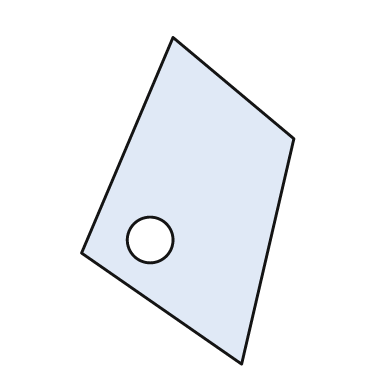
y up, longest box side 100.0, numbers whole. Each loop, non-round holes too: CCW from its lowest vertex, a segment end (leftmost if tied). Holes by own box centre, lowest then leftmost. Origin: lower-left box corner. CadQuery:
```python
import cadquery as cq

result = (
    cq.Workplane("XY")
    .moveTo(49.0, 0.0)
    .lineTo(65.0, 69.0)
    .lineTo(28.0, 100.0)
    .lineTo(0.0, 34.0)
    .close()
    .moveTo(21.0, 38.0)
    .circle(7.0)
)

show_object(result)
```